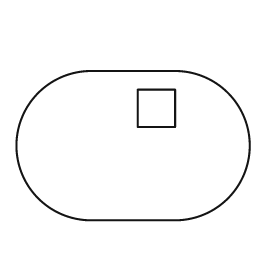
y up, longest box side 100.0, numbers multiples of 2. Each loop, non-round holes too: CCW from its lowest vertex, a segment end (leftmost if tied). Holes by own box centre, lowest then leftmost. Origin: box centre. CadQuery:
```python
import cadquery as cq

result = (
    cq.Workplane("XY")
    .moveTo(-18.0, -32.0)
    .lineTo(18.0, -32.0)
    .threePointArc((50.0, 0.0), (18.0, 32.0))
    .lineTo(-18.0, 32.0)
    .threePointArc((-50.0, 0.0), (-18.0, -32.0))
    .close()
    .moveTo(2.0, 8.0)
    .lineTo(18.0, 8.0)
    .lineTo(18.0, 24.0)
    .lineTo(2.0, 24.0)
    .close()
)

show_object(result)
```